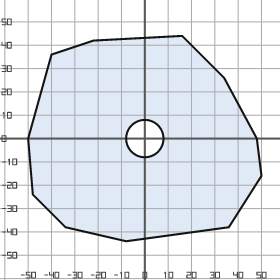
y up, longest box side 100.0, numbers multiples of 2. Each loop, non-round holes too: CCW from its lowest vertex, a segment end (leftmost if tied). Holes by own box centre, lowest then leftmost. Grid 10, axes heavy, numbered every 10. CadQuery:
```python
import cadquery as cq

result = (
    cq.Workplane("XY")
    .moveTo(-8.0, -44.0)
    .lineTo(36.0, -38.0)
    .lineTo(50.0, -16.0)
    .lineTo(48.0, 0.0)
    .lineTo(34.0, 26.0)
    .lineTo(16.0, 44.0)
    .lineTo(-22.0, 42.0)
    .lineTo(-40.0, 36.0)
    .lineTo(-50.0, 0.0)
    .lineTo(-48.0, -24.0)
    .lineTo(-34.0, -38.0)
    .close()
    .moveTo(0.0, 0.0)
    .circle(8.0)
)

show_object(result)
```